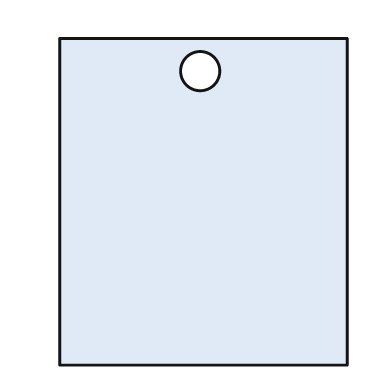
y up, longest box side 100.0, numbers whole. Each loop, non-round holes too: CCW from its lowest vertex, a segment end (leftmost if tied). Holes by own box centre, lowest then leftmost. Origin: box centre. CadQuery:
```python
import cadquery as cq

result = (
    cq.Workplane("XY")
    .moveTo(-44.0, -50.0)
    .lineTo(44.0, -50.0)
    .lineTo(44.0, 50.0)
    .lineTo(-44.0, 50.0)
    .close()
    .moveTo(-1.0, 40.0)
    .circle(6.0)
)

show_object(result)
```